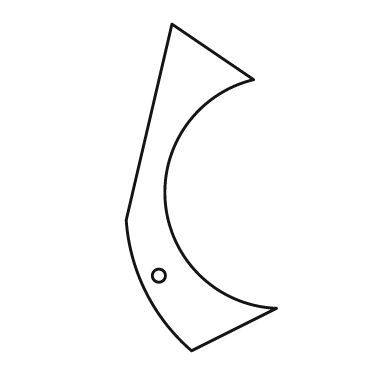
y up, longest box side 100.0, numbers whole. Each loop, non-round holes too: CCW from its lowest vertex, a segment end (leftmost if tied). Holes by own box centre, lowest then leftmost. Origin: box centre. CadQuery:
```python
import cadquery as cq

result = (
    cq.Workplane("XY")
    .moveTo(-3.0, -50.0)
    .lineTo(23.0, -37.0)
    .threePointArc((-11.0, -5.0), (16.0, 33.0))
    .lineTo(-9.0, 50.0)
    .lineTo(-23.0, -10.0)
    .threePointArc((-17.0, -32.0), (-3.0, -50.0))
    .close()
    .moveTo(-13.0, -27.0)
    .circle(2.0)
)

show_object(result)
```